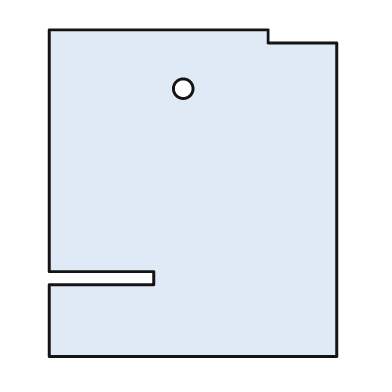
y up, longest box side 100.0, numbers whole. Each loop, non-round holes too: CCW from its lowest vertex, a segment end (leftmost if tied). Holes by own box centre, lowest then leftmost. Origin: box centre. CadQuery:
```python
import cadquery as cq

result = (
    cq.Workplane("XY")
    .moveTo(-44.0, -50.0)
    .lineTo(44.0, -50.0)
    .lineTo(44.0, 46.0)
    .lineTo(23.0, 46.0)
    .lineTo(23.0, 50.0)
    .lineTo(-44.0, 50.0)
    .lineTo(-44.0, -24.0)
    .lineTo(-12.0, -24.0)
    .lineTo(-12.0, -28.0)
    .lineTo(-44.0, -28.0)
    .close()
    .moveTo(-3.0, 32.0)
    .circle(3.0)
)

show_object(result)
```